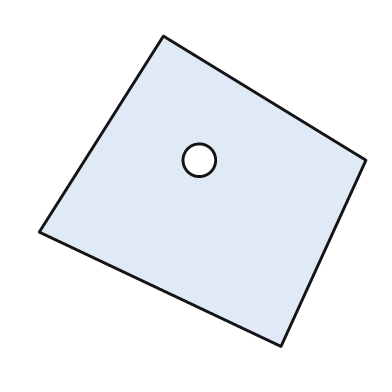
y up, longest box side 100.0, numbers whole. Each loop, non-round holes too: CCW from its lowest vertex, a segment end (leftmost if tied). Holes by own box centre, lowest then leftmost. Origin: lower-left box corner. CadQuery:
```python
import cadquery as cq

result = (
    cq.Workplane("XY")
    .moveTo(74.0, 0.0)
    .lineTo(100.0, 57.0)
    .lineTo(38.0, 95.0)
    .lineTo(0.0, 35.0)
    .close()
    .moveTo(49.0, 57.0)
    .circle(5.0)
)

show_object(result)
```